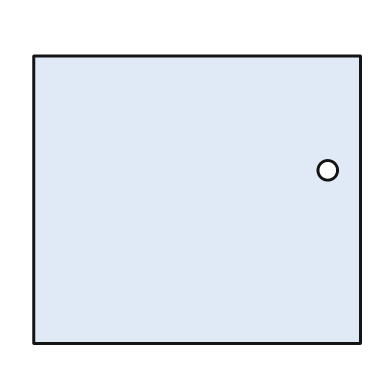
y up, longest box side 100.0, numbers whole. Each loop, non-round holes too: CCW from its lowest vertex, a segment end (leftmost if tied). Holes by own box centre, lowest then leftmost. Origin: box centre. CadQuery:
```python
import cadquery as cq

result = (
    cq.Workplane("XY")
    .moveTo(-50.0, -44.0)
    .lineTo(50.0, -44.0)
    .lineTo(50.0, 44.0)
    .lineTo(-50.0, 44.0)
    .close()
    .moveTo(40.0, 9.0)
    .circle(3.0)
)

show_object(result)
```